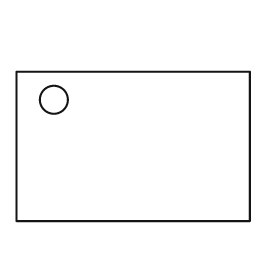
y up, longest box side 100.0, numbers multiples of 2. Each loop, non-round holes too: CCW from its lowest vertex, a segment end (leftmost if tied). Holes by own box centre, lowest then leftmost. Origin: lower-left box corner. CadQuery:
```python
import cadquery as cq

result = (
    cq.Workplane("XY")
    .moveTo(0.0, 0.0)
    .lineTo(100.0, 0.0)
    .lineTo(100.0, 64.0)
    .lineTo(0.0, 64.0)
    .close()
    .moveTo(16.0, 52.0)
    .circle(6.0)
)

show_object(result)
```